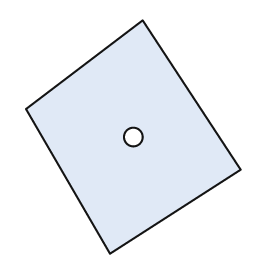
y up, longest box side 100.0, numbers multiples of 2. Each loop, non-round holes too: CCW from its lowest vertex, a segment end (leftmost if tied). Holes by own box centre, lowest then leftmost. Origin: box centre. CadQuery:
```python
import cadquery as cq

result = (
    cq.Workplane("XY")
    .moveTo(-10.0, -50.0)
    .lineTo(46.0, -14.0)
    .lineTo(4.0, 50.0)
    .lineTo(-46.0, 12.0)
    .close()
    .moveTo(0.0, 0.0)
    .circle(4.0)
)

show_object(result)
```